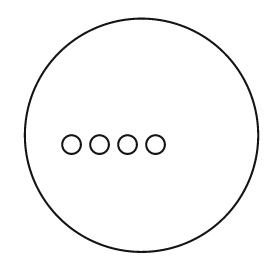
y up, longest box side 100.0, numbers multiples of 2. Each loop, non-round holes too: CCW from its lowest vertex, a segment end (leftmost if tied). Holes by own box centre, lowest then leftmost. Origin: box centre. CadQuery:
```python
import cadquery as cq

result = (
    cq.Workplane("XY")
    .moveTo(0.0, 0.0)
    .circle(50.0)
    .moveTo(-30.0, -4.0)
    .circle(4.0)
    .moveTo(-18.0, -4.0)
    .circle(4.0)
    .moveTo(-6.0, -4.0)
    .circle(4.0)
    .moveTo(6.0, -4.0)
    .circle(4.0)
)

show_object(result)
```